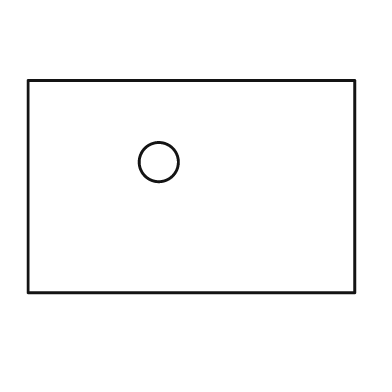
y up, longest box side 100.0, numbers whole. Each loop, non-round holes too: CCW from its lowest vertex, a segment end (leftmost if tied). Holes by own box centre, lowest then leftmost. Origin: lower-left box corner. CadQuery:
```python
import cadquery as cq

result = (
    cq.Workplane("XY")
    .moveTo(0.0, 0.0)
    .lineTo(100.0, 0.0)
    .lineTo(100.0, 65.0)
    .lineTo(0.0, 65.0)
    .close()
    .moveTo(40.0, 40.0)
    .circle(6.0)
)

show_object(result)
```